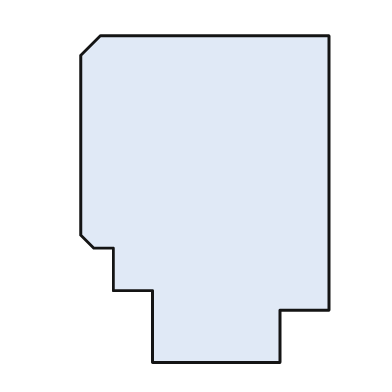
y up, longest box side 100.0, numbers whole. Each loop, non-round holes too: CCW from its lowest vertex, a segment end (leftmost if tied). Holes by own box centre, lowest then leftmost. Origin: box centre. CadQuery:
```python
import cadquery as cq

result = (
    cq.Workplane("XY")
    .moveTo(-16.0, -50.0)
    .lineTo(23.0, -50.0)
    .lineTo(23.0, -34.0)
    .lineTo(38.0, -34.0)
    .lineTo(38.0, 50.0)
    .lineTo(-32.0, 50.0)
    .lineTo(-38.0, 44.0)
    .lineTo(-38.0, -11.0)
    .lineTo(-34.0, -15.0)
    .lineTo(-28.0, -15.0)
    .lineTo(-28.0, -28.0)
    .lineTo(-16.0, -28.0)
    .close()
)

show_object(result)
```